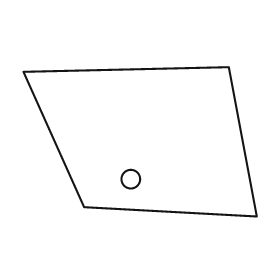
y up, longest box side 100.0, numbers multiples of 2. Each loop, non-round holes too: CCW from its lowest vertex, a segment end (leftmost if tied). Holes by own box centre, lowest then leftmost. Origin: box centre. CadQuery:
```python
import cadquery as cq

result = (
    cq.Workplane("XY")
    .moveTo(50.0, -32.0)
    .lineTo(38.0, 32.0)
    .lineTo(-50.0, 30.0)
    .lineTo(-24.0, -28.0)
    .close()
    .moveTo(-4.0, -16.0)
    .circle(4.0)
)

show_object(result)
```